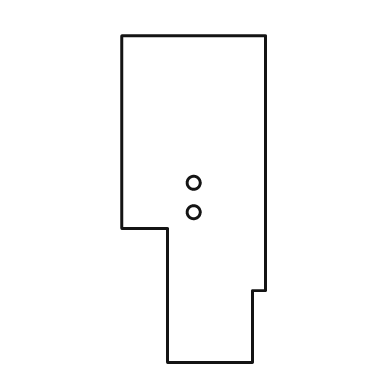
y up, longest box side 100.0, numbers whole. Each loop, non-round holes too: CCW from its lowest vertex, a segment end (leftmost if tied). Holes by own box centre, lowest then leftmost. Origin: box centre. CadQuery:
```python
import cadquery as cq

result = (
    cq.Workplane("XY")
    .moveTo(-8.0, -50.0)
    .lineTo(18.0, -50.0)
    .lineTo(18.0, -28.0)
    .lineTo(22.0, -28.0)
    .lineTo(22.0, 50.0)
    .lineTo(-22.0, 50.0)
    .lineTo(-22.0, -9.0)
    .lineTo(-8.0, -9.0)
    .close()
    .moveTo(0.0, -4.0)
    .circle(2.0)
    .moveTo(0.0, 5.0)
    .circle(2.0)
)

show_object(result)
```